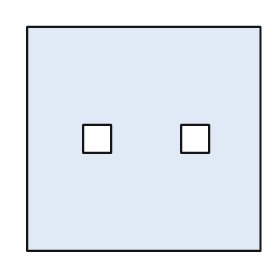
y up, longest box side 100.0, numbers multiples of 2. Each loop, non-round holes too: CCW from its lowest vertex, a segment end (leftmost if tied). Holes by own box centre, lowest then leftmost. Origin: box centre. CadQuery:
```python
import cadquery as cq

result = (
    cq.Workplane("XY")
    .moveTo(-50.0, -48.0)
    .lineTo(50.0, -48.0)
    .lineTo(50.0, 48.0)
    .lineTo(-50.0, 48.0)
    .close()
    .moveTo(-26.0, -6.0)
    .lineTo(-14.0, -6.0)
    .lineTo(-14.0, 6.0)
    .lineTo(-26.0, 6.0)
    .close()
    .moveTo(16.0, -6.0)
    .lineTo(28.0, -6.0)
    .lineTo(28.0, 6.0)
    .lineTo(16.0, 6.0)
    .close()
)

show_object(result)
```